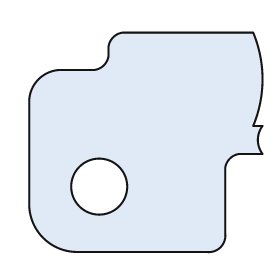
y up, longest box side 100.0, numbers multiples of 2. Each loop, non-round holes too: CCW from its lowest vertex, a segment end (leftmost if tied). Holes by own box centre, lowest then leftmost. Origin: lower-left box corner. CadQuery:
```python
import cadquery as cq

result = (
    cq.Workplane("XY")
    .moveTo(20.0, 0.0)
    .lineTo(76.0, 0.0)
    .threePointArc((82.0, 2.0), (84.0, 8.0))
    .lineTo(84.0, 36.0)
    .threePointArc((86.0, 40.0), (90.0, 42.0))
    .lineTo(100.0, 42.0)
    .threePointArc((98.0, 48.0), (100.0, 54.0))
    .lineTo(96.0, 54.0)
    .threePointArc((100.0, 74.0), (96.0, 94.0))
    .lineTo(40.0, 94.0)
    .threePointArc((36.0, 92.0), (34.0, 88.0))
    .lineTo(34.0, 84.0)
    .threePointArc((32.0, 80.0), (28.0, 78.0))
    .lineTo(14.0, 78.0)
    .threePointArc((4.0, 74.0), (0.0, 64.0))
    .lineTo(0.0, 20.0)
    .threePointArc((6.0, 6.0), (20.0, 0.0))
    .close()
    .moveTo(30.0, 28.0)
    .circle(12.0)
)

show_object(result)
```